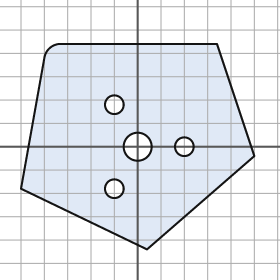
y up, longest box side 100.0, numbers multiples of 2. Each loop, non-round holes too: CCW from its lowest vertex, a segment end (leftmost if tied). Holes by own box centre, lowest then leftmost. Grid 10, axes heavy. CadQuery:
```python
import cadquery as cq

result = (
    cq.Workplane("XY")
    .moveTo(4.0, -44.0)
    .lineTo(50.0, -4.0)
    .lineTo(34.0, 44.0)
    .lineTo(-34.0, 44.0)
    .threePointArc((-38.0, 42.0), (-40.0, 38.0))
    .lineTo(-50.0, -18.0)
    .close()
    .moveTo(-10.0, -18.0)
    .circle(4.0)
    .moveTo(0.0, 0.0)
    .circle(6.0)
    .moveTo(20.0, 0.0)
    .circle(4.0)
    .moveTo(-10.0, 18.0)
    .circle(4.0)
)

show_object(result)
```